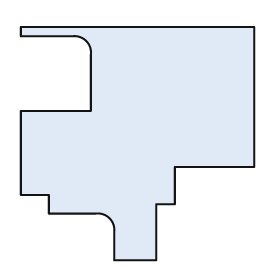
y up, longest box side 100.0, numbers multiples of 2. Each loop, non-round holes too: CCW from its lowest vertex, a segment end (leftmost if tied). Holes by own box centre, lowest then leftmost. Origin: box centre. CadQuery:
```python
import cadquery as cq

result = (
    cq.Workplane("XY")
    .moveTo(-10.0, -50.0)
    .lineTo(8.0, -50.0)
    .lineTo(8.0, -26.0)
    .lineTo(16.0, -26.0)
    .lineTo(16.0, -10.0)
    .lineTo(50.0, -10.0)
    .lineTo(50.0, 50.0)
    .lineTo(-50.0, 50.0)
    .lineTo(-50.0, 46.0)
    .lineTo(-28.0, 46.0)
    .threePointArc((-22.0, 44.0), (-20.0, 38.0))
    .lineTo(-20.0, 14.0)
    .lineTo(-50.0, 14.0)
    .lineTo(-50.0, -22.0)
    .lineTo(-38.0, -22.0)
    .lineTo(-38.0, -30.0)
    .lineTo(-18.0, -30.0)
    .threePointArc((-12.0, -32.0), (-10.0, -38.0))
    .close()
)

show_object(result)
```